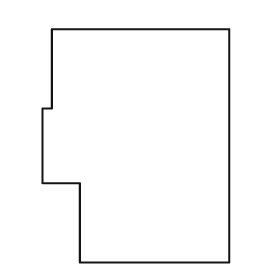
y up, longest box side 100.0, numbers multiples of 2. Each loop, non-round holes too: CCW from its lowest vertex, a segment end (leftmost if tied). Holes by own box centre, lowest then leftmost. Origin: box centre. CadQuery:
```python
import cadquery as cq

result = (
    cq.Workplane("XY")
    .moveTo(-24.0, -50.0)
    .lineTo(40.0, -50.0)
    .lineTo(40.0, 50.0)
    .lineTo(-36.0, 50.0)
    .lineTo(-36.0, 16.0)
    .lineTo(-40.0, 16.0)
    .lineTo(-40.0, -16.0)
    .lineTo(-24.0, -16.0)
    .close()
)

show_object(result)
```